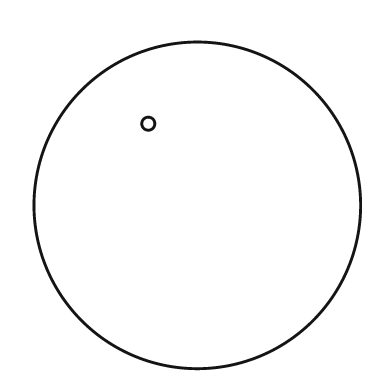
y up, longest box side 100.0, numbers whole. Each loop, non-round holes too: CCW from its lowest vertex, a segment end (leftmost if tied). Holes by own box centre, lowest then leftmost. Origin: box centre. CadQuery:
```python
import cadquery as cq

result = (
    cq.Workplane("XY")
    .moveTo(0.0, 0.0)
    .circle(50.0)
    .moveTo(-15.0, 25.0)
    .circle(2.0)
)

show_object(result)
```